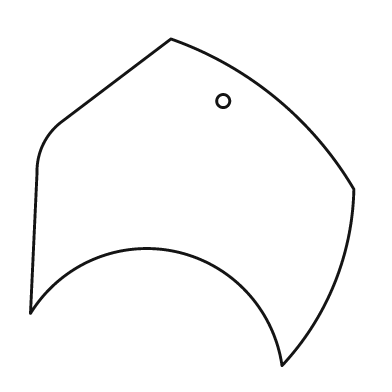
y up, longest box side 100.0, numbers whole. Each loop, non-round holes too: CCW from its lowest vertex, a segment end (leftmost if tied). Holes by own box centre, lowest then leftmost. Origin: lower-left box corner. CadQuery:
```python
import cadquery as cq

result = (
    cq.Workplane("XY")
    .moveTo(77.0, 0.0)
    .threePointArc((93.0, 25.0), (99.0, 54.0))
    .threePointArc((75.0, 82.0), (43.0, 100.0))
    .lineTo(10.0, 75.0)
    .threePointArc((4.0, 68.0), (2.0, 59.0))
    .lineTo(0.0, 16.0)
    .threePointArc((44.0, 35.0), (77.0, 0.0))
    .close()
    .moveTo(59.0, 81.0)
    .circle(2.0)
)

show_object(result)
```